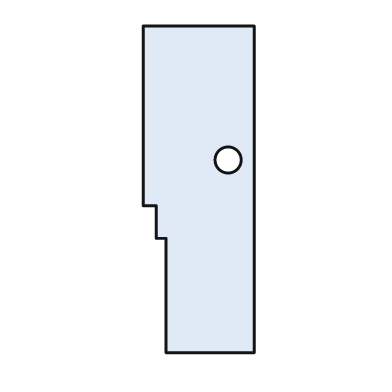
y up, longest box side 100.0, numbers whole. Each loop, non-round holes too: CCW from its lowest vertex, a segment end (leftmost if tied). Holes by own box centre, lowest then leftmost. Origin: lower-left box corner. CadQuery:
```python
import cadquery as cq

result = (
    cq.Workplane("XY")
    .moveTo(7.0, 0.0)
    .lineTo(34.0, 0.0)
    .lineTo(34.0, 100.0)
    .lineTo(0.0, 100.0)
    .lineTo(0.0, 45.0)
    .lineTo(4.0, 45.0)
    .lineTo(4.0, 35.0)
    .lineTo(7.0, 35.0)
    .close()
    .moveTo(26.0, 59.0)
    .circle(4.0)
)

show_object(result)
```